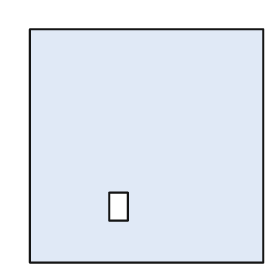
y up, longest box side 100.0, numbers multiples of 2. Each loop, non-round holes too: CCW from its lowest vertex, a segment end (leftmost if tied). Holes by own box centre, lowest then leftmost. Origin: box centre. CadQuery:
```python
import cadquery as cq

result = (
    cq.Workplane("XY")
    .moveTo(-50.0, -50.0)
    .lineTo(50.0, -50.0)
    .lineTo(50.0, 50.0)
    .lineTo(-50.0, 50.0)
    .close()
    .moveTo(-16.0, -32.0)
    .lineTo(-8.0, -32.0)
    .lineTo(-8.0, -20.0)
    .lineTo(-16.0, -20.0)
    .close()
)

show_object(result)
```